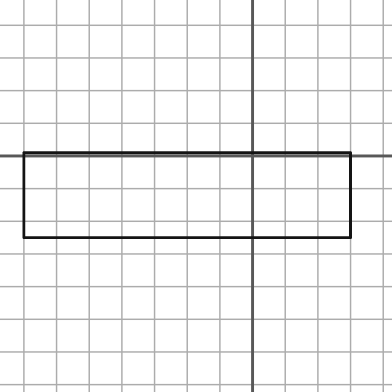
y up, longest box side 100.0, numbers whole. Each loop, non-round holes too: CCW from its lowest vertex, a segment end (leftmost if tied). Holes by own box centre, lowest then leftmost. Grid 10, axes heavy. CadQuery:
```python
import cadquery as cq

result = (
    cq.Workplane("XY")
    .moveTo(-70.0, -25.0)
    .lineTo(30.0, -25.0)
    .lineTo(30.0, 1.0)
    .lineTo(-70.0, 1.0)
    .close()
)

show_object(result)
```